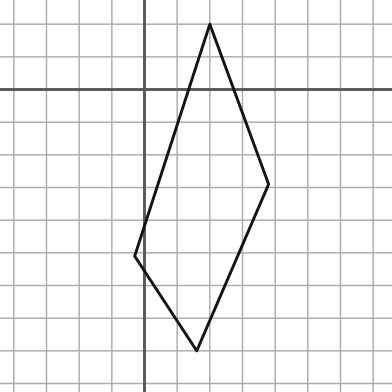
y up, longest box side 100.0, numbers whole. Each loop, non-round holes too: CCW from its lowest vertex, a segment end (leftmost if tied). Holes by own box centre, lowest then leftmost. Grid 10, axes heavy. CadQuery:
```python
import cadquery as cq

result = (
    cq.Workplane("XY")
    .moveTo(16.0, -80.0)
    .lineTo(38.0, -29.0)
    .lineTo(20.0, 20.0)
    .lineTo(-3.0, -51.0)
    .close()
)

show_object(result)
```